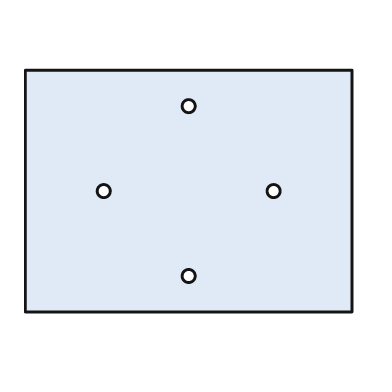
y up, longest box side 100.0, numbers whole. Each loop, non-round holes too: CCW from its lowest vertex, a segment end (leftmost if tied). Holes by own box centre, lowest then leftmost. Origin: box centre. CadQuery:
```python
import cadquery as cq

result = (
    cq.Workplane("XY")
    .moveTo(-50.0, -37.0)
    .lineTo(50.0, -37.0)
    .lineTo(50.0, 37.0)
    .lineTo(-50.0, 37.0)
    .close()
    .moveTo(0.0, -26.0)
    .circle(2.0)
    .moveTo(-26.0, 0.0)
    .circle(2.0)
    .moveTo(26.0, 0.0)
    .circle(2.0)
    .moveTo(0.0, 26.0)
    .circle(2.0)
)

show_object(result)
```